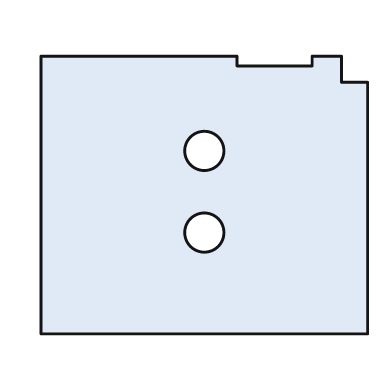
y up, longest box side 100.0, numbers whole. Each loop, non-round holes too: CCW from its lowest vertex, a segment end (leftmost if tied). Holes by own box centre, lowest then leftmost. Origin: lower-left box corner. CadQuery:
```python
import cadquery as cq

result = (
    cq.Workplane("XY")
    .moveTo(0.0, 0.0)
    .lineTo(100.0, 0.0)
    .lineTo(100.0, 77.0)
    .lineTo(92.0, 77.0)
    .lineTo(92.0, 85.0)
    .lineTo(83.0, 85.0)
    .lineTo(83.0, 82.0)
    .lineTo(60.0, 82.0)
    .lineTo(60.0, 85.0)
    .lineTo(0.0, 85.0)
    .close()
    .moveTo(50.0, 31.0)
    .circle(6.0)
    .moveTo(50.0, 56.0)
    .circle(6.0)
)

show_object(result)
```